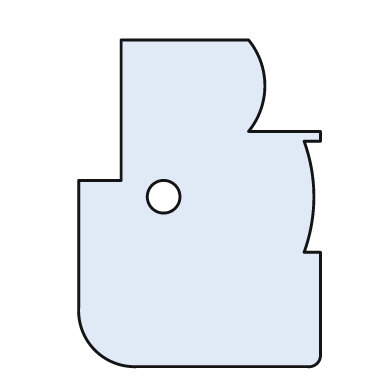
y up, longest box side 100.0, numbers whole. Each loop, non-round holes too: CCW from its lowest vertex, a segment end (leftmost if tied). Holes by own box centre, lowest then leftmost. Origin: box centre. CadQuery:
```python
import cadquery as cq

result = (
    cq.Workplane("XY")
    .moveTo(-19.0, -50.0)
    .lineTo(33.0, -50.0)
    .threePointArc((36.0, -49.0), (37.0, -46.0))
    .lineTo(37.0, -15.0)
    .lineTo(32.0, -15.0)
    .threePointArc((35.0, 2.0), (32.0, 19.0))
    .lineTo(37.0, 19.0)
    .lineTo(37.0, 22.0)
    .lineTo(15.0, 22.0)
    .threePointArc((20.0, 36.0), (15.0, 50.0))
    .lineTo(-24.0, 50.0)
    .lineTo(-24.0, 7.0)
    .lineTo(-37.0, 7.0)
    .lineTo(-37.0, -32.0)
    .threePointArc((-32.0, -45.0), (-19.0, -50.0))
    .close()
    .moveTo(-11.0, 2.0)
    .circle(5.0)
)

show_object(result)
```